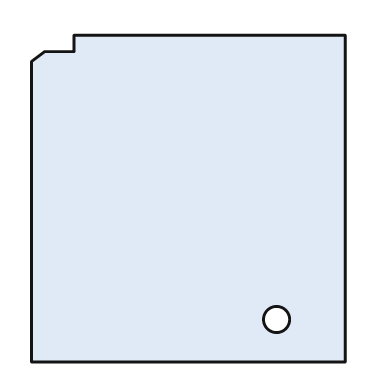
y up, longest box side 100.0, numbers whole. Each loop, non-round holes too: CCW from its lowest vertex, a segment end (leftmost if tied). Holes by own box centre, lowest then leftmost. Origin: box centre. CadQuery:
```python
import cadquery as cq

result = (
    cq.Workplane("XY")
    .moveTo(-48.0, -50.0)
    .lineTo(48.0, -50.0)
    .lineTo(48.0, 50.0)
    .lineTo(-35.0, 50.0)
    .lineTo(-35.0, 45.0)
    .lineTo(-44.0, 45.0)
    .lineTo(-48.0, 42.0)
    .close()
    .moveTo(27.0, -37.0)
    .circle(4.0)
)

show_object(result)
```